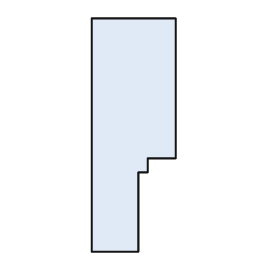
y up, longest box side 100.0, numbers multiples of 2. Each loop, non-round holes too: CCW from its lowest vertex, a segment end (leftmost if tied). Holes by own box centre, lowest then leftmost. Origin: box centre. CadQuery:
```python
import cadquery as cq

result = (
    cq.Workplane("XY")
    .moveTo(-18.0, -50.0)
    .lineTo(2.0, -50.0)
    .lineTo(2.0, -16.0)
    .lineTo(6.0, -16.0)
    .lineTo(6.0, -10.0)
    .lineTo(18.0, -10.0)
    .lineTo(18.0, 50.0)
    .lineTo(-18.0, 50.0)
    .close()
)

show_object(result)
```